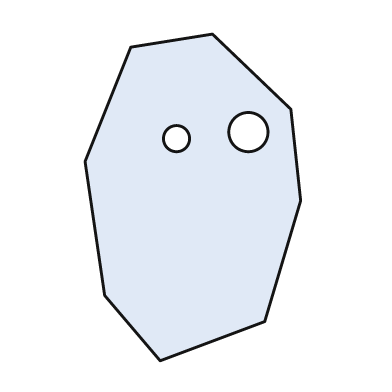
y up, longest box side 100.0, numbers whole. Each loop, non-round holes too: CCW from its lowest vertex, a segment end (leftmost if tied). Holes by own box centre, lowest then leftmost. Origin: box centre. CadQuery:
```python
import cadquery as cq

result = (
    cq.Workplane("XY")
    .moveTo(-10.0, -50.0)
    .lineTo(22.0, -38.0)
    .lineTo(33.0, -1.0)
    .lineTo(30.0, 27.0)
    .lineTo(6.0, 50.0)
    .lineTo(-19.0, 46.0)
    .lineTo(-33.0, 11.0)
    .lineTo(-27.0, -30.0)
    .close()
    .moveTo(-5.0, 18.0)
    .circle(4.0)
    .moveTo(17.0, 20.0)
    .circle(6.0)
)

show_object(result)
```